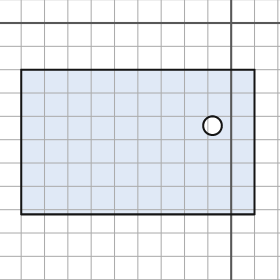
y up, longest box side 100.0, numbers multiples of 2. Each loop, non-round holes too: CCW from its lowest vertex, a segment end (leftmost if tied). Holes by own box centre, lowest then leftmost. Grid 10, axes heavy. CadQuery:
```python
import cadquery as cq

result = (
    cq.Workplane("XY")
    .moveTo(-90.0, -82.0)
    .lineTo(10.0, -82.0)
    .lineTo(10.0, -20.0)
    .lineTo(-90.0, -20.0)
    .close()
    .moveTo(-8.0, -44.0)
    .circle(4.0)
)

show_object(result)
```